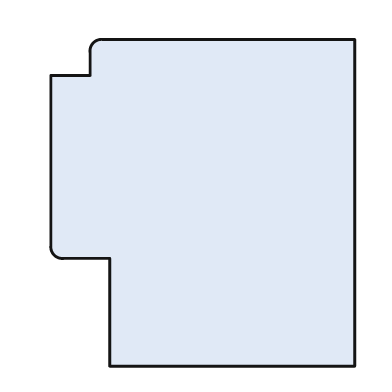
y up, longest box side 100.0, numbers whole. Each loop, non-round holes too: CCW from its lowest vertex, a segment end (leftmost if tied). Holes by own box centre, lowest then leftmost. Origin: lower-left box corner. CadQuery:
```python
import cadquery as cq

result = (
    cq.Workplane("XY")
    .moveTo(18.0, 0.0)
    .lineTo(93.0, 0.0)
    .lineTo(93.0, 100.0)
    .lineTo(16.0, 100.0)
    .threePointArc((13.0, 99.0), (12.0, 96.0))
    .lineTo(12.0, 89.0)
    .lineTo(0.0, 89.0)
    .lineTo(0.0, 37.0)
    .threePointArc((1.0, 34.0), (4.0, 33.0))
    .lineTo(18.0, 33.0)
    .close()
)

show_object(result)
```